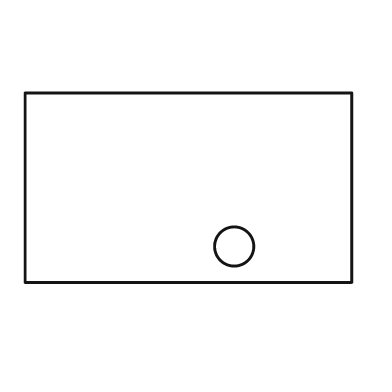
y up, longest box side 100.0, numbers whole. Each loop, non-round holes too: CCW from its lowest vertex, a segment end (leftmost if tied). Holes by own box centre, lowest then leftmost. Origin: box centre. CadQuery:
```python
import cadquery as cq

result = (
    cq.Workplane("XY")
    .moveTo(-50.0, -29.0)
    .lineTo(50.0, -29.0)
    .lineTo(50.0, 29.0)
    .lineTo(-50.0, 29.0)
    .close()
    .moveTo(14.0, -18.0)
    .circle(6.0)
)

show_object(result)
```